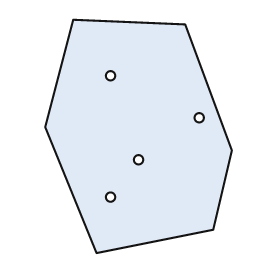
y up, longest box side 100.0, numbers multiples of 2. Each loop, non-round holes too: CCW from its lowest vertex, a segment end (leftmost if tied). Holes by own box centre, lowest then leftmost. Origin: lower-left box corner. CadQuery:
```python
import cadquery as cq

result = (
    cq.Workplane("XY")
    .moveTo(22.0, 0.0)
    .lineTo(72.0, 10.0)
    .lineTo(80.0, 44.0)
    .lineTo(60.0, 98.0)
    .lineTo(12.0, 100.0)
    .lineTo(0.0, 54.0)
    .close()
    .moveTo(28.0, 24.0)
    .circle(2.0)
    .moveTo(40.0, 40.0)
    .circle(2.0)
    .moveTo(66.0, 58.0)
    .circle(2.0)
    .moveTo(28.0, 76.0)
    .circle(2.0)
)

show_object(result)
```